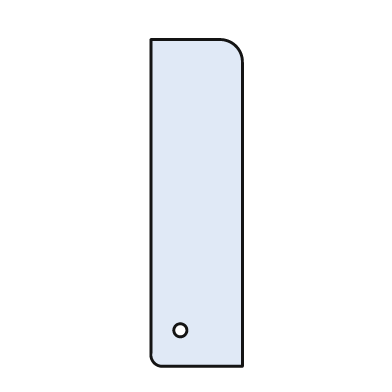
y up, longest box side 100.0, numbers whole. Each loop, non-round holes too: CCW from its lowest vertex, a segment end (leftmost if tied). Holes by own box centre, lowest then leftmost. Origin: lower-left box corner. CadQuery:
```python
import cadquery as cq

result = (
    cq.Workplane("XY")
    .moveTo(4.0, 0.0)
    .lineTo(28.0, 0.0)
    .lineTo(28.0, 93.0)
    .threePointArc((26.0, 98.0), (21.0, 100.0))
    .lineTo(0.0, 100.0)
    .lineTo(0.0, 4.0)
    .threePointArc((1.0, 1.0), (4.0, 0.0))
    .close()
    .moveTo(9.0, 11.0)
    .circle(2.0)
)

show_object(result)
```